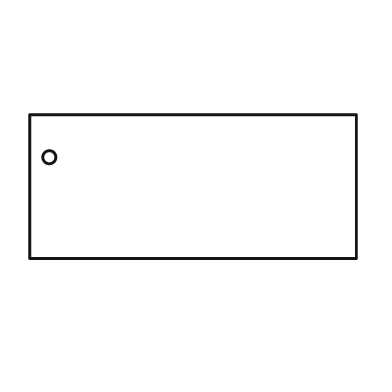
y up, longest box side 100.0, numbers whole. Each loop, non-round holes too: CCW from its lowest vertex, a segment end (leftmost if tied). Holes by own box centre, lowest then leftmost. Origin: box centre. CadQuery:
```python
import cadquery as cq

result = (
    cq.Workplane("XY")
    .moveTo(-50.0, -22.0)
    .lineTo(50.0, -22.0)
    .lineTo(50.0, 22.0)
    .lineTo(-50.0, 22.0)
    .close()
    .moveTo(-44.0, 9.0)
    .circle(2.0)
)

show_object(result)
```